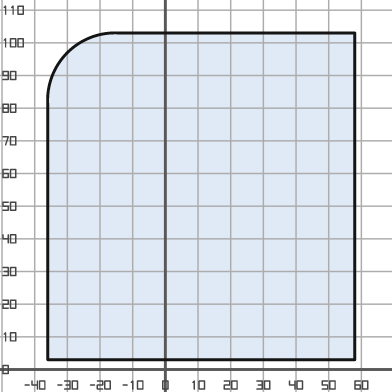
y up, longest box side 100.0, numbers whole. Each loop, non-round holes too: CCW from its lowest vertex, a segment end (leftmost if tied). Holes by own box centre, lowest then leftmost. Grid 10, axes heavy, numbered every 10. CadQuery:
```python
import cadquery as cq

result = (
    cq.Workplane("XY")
    .moveTo(-36.0, 3.0)
    .lineTo(58.0, 3.0)
    .lineTo(58.0, 103.0)
    .lineTo(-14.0, 103.0)
    .threePointArc((-30.0, 97.0), (-36.0, 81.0))
    .close()
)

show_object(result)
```